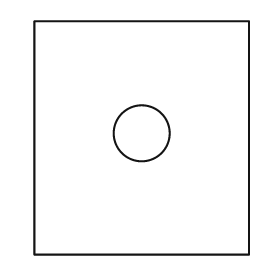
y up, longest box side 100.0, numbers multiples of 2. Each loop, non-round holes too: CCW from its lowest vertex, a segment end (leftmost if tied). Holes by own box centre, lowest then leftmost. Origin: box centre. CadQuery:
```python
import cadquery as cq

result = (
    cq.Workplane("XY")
    .moveTo(-46.0, -50.0)
    .lineTo(46.0, -50.0)
    .lineTo(46.0, 50.0)
    .lineTo(-46.0, 50.0)
    .close()
    .moveTo(0.0, 2.0)
    .circle(12.0)
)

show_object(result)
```